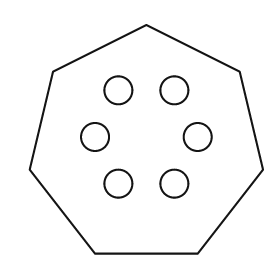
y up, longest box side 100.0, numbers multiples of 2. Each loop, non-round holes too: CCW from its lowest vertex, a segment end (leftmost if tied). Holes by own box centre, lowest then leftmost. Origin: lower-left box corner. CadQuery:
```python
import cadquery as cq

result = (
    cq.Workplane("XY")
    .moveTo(28.0, 0.0)
    .lineTo(72.0, 0.0)
    .lineTo(100.0, 36.0)
    .lineTo(90.0, 78.0)
    .lineTo(50.0, 98.0)
    .lineTo(10.0, 78.0)
    .lineTo(0.0, 36.0)
    .close()
    .moveTo(38.0, 30.0)
    .circle(6.0)
    .moveTo(62.0, 30.0)
    .circle(6.0)
    .moveTo(28.0, 50.0)
    .circle(6.0)
    .moveTo(72.0, 50.0)
    .circle(6.0)
    .moveTo(38.0, 70.0)
    .circle(6.0)
    .moveTo(62.0, 70.0)
    .circle(6.0)
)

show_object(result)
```